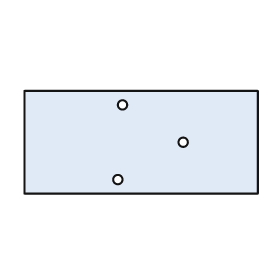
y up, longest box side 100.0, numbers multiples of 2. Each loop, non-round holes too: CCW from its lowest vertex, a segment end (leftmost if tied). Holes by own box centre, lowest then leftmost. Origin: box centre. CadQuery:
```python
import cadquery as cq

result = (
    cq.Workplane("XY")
    .moveTo(-50.0, -22.0)
    .lineTo(50.0, -22.0)
    .lineTo(50.0, 22.0)
    .lineTo(-50.0, 22.0)
    .close()
    .moveTo(-10.0, -16.0)
    .circle(2.0)
    .moveTo(18.0, 0.0)
    .circle(2.0)
    .moveTo(-8.0, 16.0)
    .circle(2.0)
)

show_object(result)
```